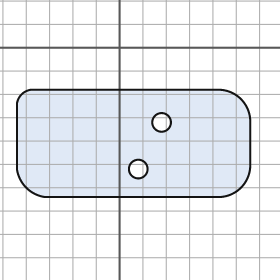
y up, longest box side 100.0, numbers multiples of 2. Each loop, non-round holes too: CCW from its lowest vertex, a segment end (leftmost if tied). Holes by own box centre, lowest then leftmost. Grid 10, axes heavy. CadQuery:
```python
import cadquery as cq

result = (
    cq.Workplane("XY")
    .moveTo(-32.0, -64.0)
    .lineTo(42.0, -64.0)
    .threePointArc((52.0, -60.0), (56.0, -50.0))
    .lineTo(56.0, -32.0)
    .threePointArc((52.0, -22.0), (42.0, -18.0))
    .lineTo(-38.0, -18.0)
    .threePointArc((-42.0, -20.0), (-44.0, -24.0))
    .lineTo(-44.0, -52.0)
    .threePointArc((-40.0, -60.0), (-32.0, -64.0))
    .close()
    .moveTo(8.0, -52.0)
    .circle(4.0)
    .moveTo(18.0, -32.0)
    .circle(4.0)
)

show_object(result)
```